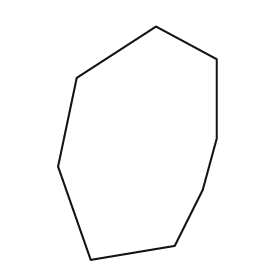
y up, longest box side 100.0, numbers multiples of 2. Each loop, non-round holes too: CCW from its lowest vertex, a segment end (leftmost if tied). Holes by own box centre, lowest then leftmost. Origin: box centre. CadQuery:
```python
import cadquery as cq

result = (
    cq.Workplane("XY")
    .moveTo(-20.0, -50.0)
    .lineTo(16.0, -44.0)
    .lineTo(28.0, -20.0)
    .lineTo(34.0, 2.0)
    .lineTo(34.0, 36.0)
    .lineTo(8.0, 50.0)
    .lineTo(-26.0, 28.0)
    .lineTo(-34.0, -10.0)
    .close()
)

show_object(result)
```